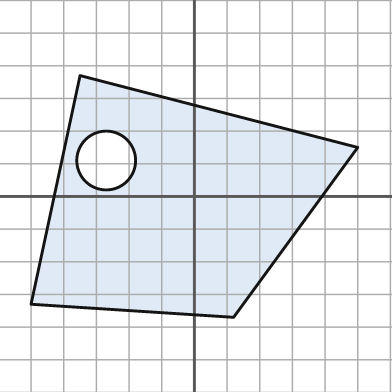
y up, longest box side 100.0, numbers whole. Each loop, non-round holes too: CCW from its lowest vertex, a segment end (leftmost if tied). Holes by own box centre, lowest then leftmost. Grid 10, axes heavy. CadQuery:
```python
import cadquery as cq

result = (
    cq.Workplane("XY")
    .moveTo(12.0, -37.0)
    .lineTo(50.0, 15.0)
    .lineTo(-35.0, 37.0)
    .lineTo(-50.0, -33.0)
    .close()
    .moveTo(-27.0, 11.0)
    .circle(9.0)
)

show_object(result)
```